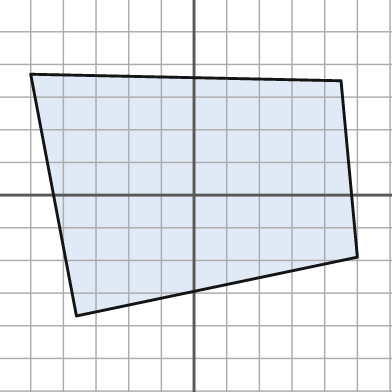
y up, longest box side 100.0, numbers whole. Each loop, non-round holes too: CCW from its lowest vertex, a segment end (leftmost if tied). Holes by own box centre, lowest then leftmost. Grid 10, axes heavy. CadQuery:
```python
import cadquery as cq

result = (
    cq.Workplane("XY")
    .moveTo(-36.0, -37.0)
    .lineTo(50.0, -19.0)
    .lineTo(45.0, 35.0)
    .lineTo(-50.0, 37.0)
    .close()
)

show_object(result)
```